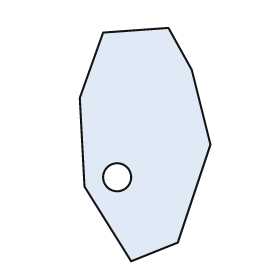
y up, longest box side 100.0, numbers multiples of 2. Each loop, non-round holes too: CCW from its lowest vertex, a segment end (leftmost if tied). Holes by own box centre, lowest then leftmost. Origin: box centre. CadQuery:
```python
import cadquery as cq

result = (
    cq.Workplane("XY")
    .moveTo(-6.0, -50.0)
    .lineTo(14.0, -42.0)
    .lineTo(28.0, 0.0)
    .lineTo(20.0, 32.0)
    .lineTo(10.0, 50.0)
    .lineTo(-18.0, 48.0)
    .lineTo(-28.0, 20.0)
    .lineTo(-26.0, -18.0)
    .close()
    .moveTo(-12.0, -14.0)
    .circle(6.0)
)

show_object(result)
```